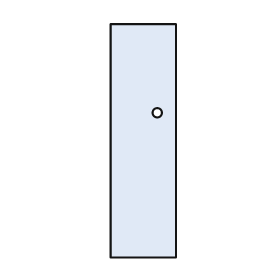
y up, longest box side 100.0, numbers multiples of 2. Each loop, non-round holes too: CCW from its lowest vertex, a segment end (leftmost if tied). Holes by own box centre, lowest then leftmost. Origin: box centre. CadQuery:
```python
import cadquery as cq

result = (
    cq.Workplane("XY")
    .moveTo(-14.0, -50.0)
    .lineTo(14.0, -50.0)
    .lineTo(14.0, 50.0)
    .lineTo(-14.0, 50.0)
    .close()
    .moveTo(6.0, 12.0)
    .circle(2.0)
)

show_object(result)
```